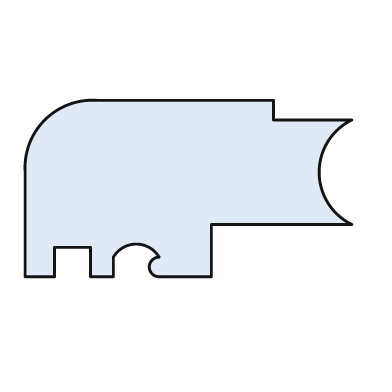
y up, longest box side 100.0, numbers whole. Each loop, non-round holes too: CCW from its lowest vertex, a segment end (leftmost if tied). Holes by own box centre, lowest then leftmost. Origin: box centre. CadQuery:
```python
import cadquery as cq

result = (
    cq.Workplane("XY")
    .moveTo(-50.0, -27.0)
    .lineTo(-41.0, -27.0)
    .lineTo(-41.0, -18.0)
    .lineTo(-30.0, -18.0)
    .lineTo(-30.0, -27.0)
    .lineTo(-23.0, -27.0)
    .lineTo(-23.0, -21.0)
    .threePointArc((-16.0, -17.0), (-9.0, -21.0))
    .threePointArc((-12.0, -24.0), (-9.0, -27.0))
    .lineTo(7.0, -27.0)
    .lineTo(7.0, -11.0)
    .lineTo(50.0, -11.0)
    .threePointArc((40.0, 5.0), (50.0, 21.0))
    .lineTo(26.0, 21.0)
    .lineTo(26.0, 27.0)
    .lineTo(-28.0, 27.0)
    .threePointArc((-44.0, 21.0), (-50.0, 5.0))
    .close()
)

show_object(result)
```